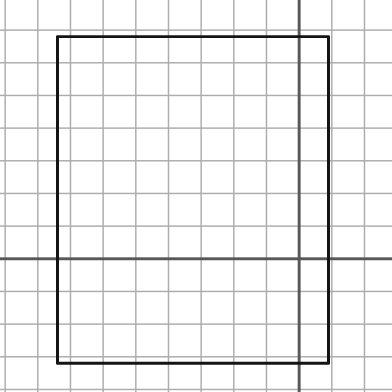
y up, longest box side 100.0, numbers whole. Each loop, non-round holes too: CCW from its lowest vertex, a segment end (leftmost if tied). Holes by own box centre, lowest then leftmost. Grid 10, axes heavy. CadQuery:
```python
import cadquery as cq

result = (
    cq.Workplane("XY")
    .moveTo(-74.0, -32.0)
    .lineTo(9.0, -32.0)
    .lineTo(9.0, 68.0)
    .lineTo(-74.0, 68.0)
    .close()
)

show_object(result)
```